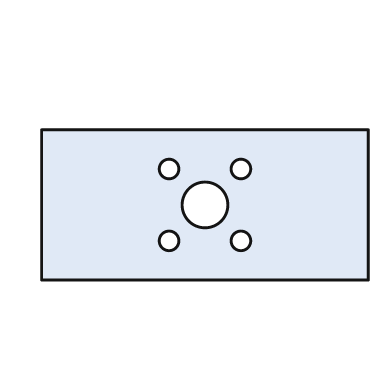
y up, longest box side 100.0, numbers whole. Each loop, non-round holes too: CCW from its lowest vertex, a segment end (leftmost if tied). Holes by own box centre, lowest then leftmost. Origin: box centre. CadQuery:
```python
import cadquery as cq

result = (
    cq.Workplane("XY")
    .moveTo(-50.0, -23.0)
    .lineTo(50.0, -23.0)
    .lineTo(50.0, 23.0)
    .lineTo(-50.0, 23.0)
    .close()
    .moveTo(-11.0, -11.0)
    .circle(3.0)
    .moveTo(11.0, -11.0)
    .circle(3.0)
    .moveTo(0.0, 0.0)
    .circle(7.0)
    .moveTo(-11.0, 11.0)
    .circle(3.0)
    .moveTo(11.0, 11.0)
    .circle(3.0)
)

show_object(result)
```